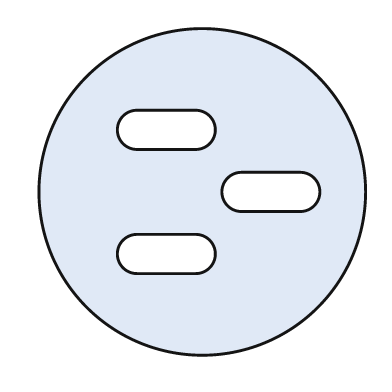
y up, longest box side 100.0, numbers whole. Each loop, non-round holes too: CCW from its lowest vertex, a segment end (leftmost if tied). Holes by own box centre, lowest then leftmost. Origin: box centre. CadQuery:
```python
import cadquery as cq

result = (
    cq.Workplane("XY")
    .moveTo(0.0, 0.0)
    .circle(50.0)
    .moveTo(-20.0, -25.0)
    .lineTo(-2.0, -25.0)
    .threePointArc((4.0, -19.0), (-2.0, -13.0))
    .lineTo(-20.0, -13.0)
    .threePointArc((-26.0, -19.0), (-20.0, -25.0))
    .close()
    .moveTo(12.0, -6.0)
    .lineTo(30.0, -6.0)
    .threePointArc((36.0, 0.0), (30.0, 6.0))
    .lineTo(12.0, 6.0)
    .threePointArc((6.0, 0.0), (12.0, -6.0))
    .close()
    .moveTo(-20.0, 13.0)
    .lineTo(-2.0, 13.0)
    .threePointArc((4.0, 19.0), (-2.0, 25.0))
    .lineTo(-20.0, 25.0)
    .threePointArc((-26.0, 19.0), (-20.0, 13.0))
    .close()
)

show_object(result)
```